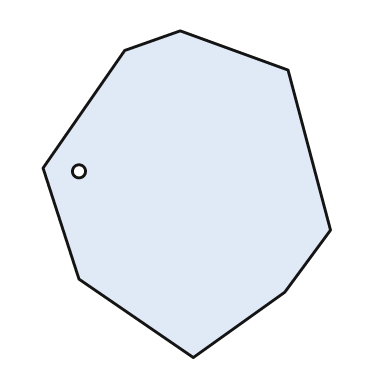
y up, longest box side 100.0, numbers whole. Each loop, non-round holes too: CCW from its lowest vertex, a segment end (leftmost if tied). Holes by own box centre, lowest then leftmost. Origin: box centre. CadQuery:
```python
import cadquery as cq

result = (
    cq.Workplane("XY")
    .moveTo(2.0, -50.0)
    .lineTo(30.0, -30.0)
    .lineTo(44.0, -11.0)
    .lineTo(31.0, 38.0)
    .lineTo(-2.0, 50.0)
    .lineTo(-19.0, 44.0)
    .lineTo(-44.0, 8.0)
    .lineTo(-33.0, -26.0)
    .close()
    .moveTo(-33.0, 7.0)
    .circle(2.0)
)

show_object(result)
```